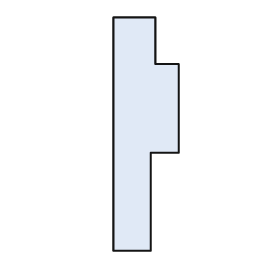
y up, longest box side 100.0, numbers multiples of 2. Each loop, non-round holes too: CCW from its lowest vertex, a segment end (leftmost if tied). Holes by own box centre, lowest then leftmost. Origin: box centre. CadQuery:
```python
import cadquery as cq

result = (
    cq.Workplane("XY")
    .moveTo(-14.0, -50.0)
    .lineTo(2.0, -50.0)
    .lineTo(2.0, -8.0)
    .lineTo(14.0, -8.0)
    .lineTo(14.0, 30.0)
    .lineTo(4.0, 30.0)
    .lineTo(4.0, 50.0)
    .lineTo(-14.0, 50.0)
    .close()
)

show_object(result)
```